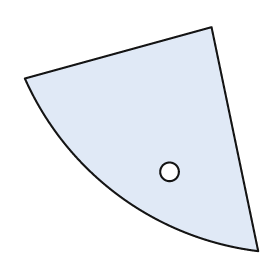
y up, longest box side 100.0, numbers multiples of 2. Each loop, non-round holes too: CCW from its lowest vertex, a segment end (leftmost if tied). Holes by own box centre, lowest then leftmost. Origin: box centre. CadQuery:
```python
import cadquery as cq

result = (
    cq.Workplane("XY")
    .moveTo(50.0, -48.0)
    .lineTo(30.0, 48.0)
    .lineTo(-50.0, 26.0)
    .threePointArc((-10.0, -24.0), (50.0, -48.0))
    .close()
    .moveTo(12.0, -14.0)
    .circle(4.0)
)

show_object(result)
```